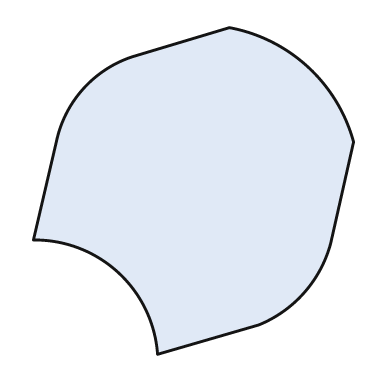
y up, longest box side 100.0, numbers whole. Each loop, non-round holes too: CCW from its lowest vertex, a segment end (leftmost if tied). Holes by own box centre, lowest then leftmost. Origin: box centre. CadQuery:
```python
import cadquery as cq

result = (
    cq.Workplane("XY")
    .moveTo(-11.0, -50.0)
    .lineTo(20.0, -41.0)
    .threePointArc((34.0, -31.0), (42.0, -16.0))
    .lineTo(49.0, 15.0)
    .threePointArc((35.0, 38.0), (11.0, 50.0))
    .lineTo(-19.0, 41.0)
    .threePointArc((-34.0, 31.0), (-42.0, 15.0))
    .lineTo(-49.0, -15.0)
    .threePointArc((-23.0, -25.0), (-11.0, -50.0))
    .close()
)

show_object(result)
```